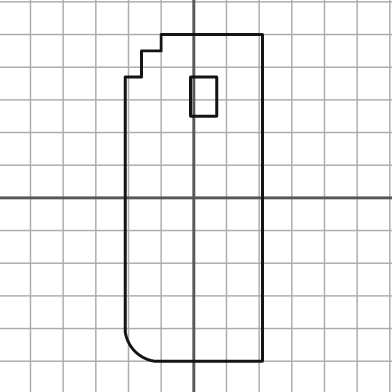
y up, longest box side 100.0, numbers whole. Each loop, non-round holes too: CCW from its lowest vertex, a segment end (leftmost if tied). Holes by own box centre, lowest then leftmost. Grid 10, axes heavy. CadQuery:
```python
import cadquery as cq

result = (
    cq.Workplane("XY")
    .moveTo(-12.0, -50.0)
    .lineTo(21.0, -50.0)
    .lineTo(21.0, 50.0)
    .lineTo(-10.0, 50.0)
    .lineTo(-10.0, 45.0)
    .lineTo(-16.0, 45.0)
    .lineTo(-16.0, 37.0)
    .lineTo(-21.0, 37.0)
    .lineTo(-21.0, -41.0)
    .threePointArc((-18.0, -47.0), (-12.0, -50.0))
    .close()
    .moveTo(-1.0, 25.0)
    .lineTo(7.0, 25.0)
    .lineTo(7.0, 37.0)
    .lineTo(-1.0, 37.0)
    .close()
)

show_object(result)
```